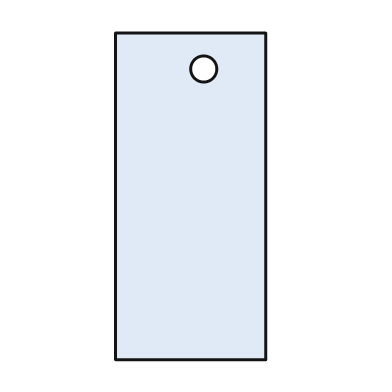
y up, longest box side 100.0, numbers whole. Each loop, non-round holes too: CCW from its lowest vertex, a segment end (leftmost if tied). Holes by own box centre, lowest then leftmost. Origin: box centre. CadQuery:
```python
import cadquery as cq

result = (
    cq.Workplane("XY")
    .moveTo(-23.0, -50.0)
    .lineTo(23.0, -50.0)
    .lineTo(23.0, 50.0)
    .lineTo(-23.0, 50.0)
    .close()
    .moveTo(4.0, 39.0)
    .circle(4.0)
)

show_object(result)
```